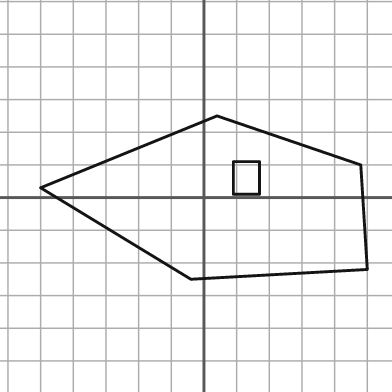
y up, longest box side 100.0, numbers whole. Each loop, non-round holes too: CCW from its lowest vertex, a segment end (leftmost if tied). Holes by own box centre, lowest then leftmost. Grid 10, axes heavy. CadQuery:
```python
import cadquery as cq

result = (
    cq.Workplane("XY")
    .moveTo(-4.0, -25.0)
    .lineTo(50.0, -22.0)
    .lineTo(48.0, 10.0)
    .lineTo(4.0, 25.0)
    .lineTo(-50.0, 3.0)
    .close()
    .moveTo(9.0, 1.0)
    .lineTo(17.0, 1.0)
    .lineTo(17.0, 11.0)
    .lineTo(9.0, 11.0)
    .close()
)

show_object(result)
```